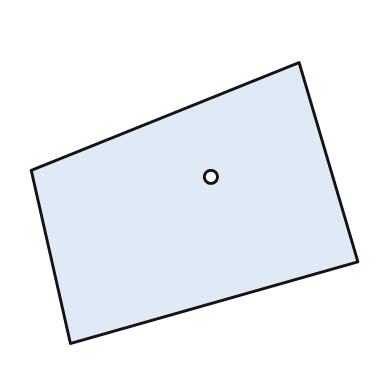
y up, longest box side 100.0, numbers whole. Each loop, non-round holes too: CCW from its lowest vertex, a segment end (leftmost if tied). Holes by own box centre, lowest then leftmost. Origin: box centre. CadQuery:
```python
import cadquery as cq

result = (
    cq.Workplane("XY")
    .moveTo(-38.0, -43.0)
    .lineTo(50.0, -18.0)
    .lineTo(32.0, 43.0)
    .lineTo(-50.0, 10.0)
    .close()
    .moveTo(5.0, 8.0)
    .circle(2.0)
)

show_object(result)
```